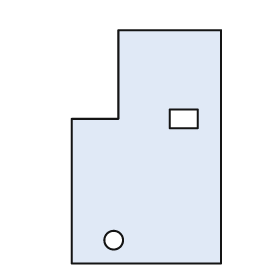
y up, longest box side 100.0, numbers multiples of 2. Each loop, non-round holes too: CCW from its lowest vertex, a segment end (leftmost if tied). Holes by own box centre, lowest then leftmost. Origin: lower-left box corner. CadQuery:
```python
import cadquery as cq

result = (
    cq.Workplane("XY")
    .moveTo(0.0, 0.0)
    .lineTo(64.0, 0.0)
    .lineTo(64.0, 100.0)
    .lineTo(20.0, 100.0)
    .lineTo(20.0, 62.0)
    .lineTo(0.0, 62.0)
    .close()
    .moveTo(18.0, 10.0)
    .circle(4.0)
    .moveTo(42.0, 58.0)
    .lineTo(54.0, 58.0)
    .lineTo(54.0, 66.0)
    .lineTo(42.0, 66.0)
    .close()
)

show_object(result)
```